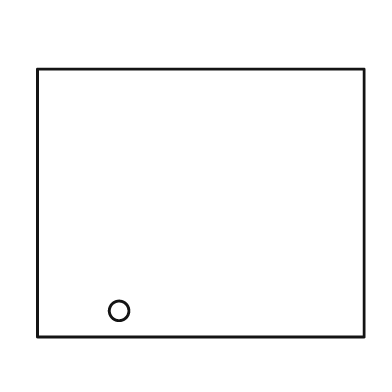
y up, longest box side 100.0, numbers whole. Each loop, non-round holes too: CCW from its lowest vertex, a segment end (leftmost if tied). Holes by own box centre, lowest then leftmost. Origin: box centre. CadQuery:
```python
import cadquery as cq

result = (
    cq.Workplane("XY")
    .moveTo(-50.0, -41.0)
    .lineTo(50.0, -41.0)
    .lineTo(50.0, 41.0)
    .lineTo(-50.0, 41.0)
    .close()
    .moveTo(-25.0, -33.0)
    .circle(3.0)
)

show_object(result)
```